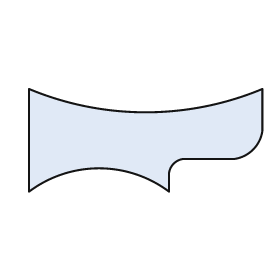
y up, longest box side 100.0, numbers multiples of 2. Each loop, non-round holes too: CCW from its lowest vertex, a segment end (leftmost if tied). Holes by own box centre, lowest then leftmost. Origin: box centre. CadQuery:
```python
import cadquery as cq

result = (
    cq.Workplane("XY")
    .moveTo(-50.0, -22.0)
    .threePointArc((-20.0, -12.0), (10.0, -22.0))
    .lineTo(10.0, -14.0)
    .threePointArc((12.0, -10.0), (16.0, -8.0))
    .lineTo(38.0, -8.0)
    .threePointArc((46.0, -4.0), (50.0, 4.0))
    .lineTo(50.0, 22.0)
    .threePointArc((0.0, 12.0), (-50.0, 22.0))
    .close()
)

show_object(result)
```